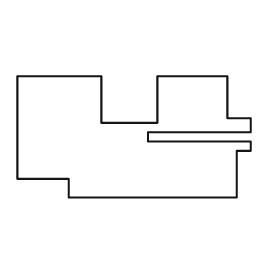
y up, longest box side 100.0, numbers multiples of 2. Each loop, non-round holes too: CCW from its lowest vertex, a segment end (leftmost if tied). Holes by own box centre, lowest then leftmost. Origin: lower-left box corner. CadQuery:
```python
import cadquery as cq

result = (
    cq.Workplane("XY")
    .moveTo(22.0, 0.0)
    .lineTo(94.0, 0.0)
    .lineTo(94.0, 20.0)
    .lineTo(100.0, 20.0)
    .lineTo(100.0, 24.0)
    .lineTo(56.0, 24.0)
    .lineTo(56.0, 28.0)
    .lineTo(100.0, 28.0)
    .lineTo(100.0, 34.0)
    .lineTo(90.0, 34.0)
    .lineTo(90.0, 52.0)
    .lineTo(60.0, 52.0)
    .lineTo(60.0, 32.0)
    .lineTo(36.0, 32.0)
    .lineTo(36.0, 52.0)
    .lineTo(0.0, 52.0)
    .lineTo(0.0, 8.0)
    .lineTo(22.0, 8.0)
    .close()
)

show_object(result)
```